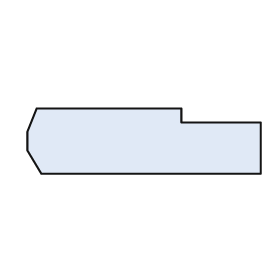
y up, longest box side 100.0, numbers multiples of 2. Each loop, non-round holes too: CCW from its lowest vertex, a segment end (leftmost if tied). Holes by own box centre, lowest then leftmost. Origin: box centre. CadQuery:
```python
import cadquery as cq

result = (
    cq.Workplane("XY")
    .moveTo(-44.0, -14.0)
    .lineTo(50.0, -14.0)
    .lineTo(50.0, 8.0)
    .lineTo(16.0, 8.0)
    .lineTo(16.0, 14.0)
    .lineTo(-46.0, 14.0)
    .lineTo(-50.0, 4.0)
    .lineTo(-50.0, -4.0)
    .close()
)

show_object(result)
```